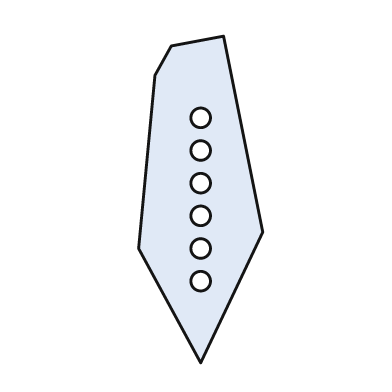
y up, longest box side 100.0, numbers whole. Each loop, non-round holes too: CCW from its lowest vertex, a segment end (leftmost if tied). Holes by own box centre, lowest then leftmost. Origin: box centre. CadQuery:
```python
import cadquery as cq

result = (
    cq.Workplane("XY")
    .moveTo(0.0, -50.0)
    .lineTo(19.0, -10.0)
    .lineTo(7.0, 50.0)
    .lineTo(-9.0, 47.0)
    .lineTo(-14.0, 38.0)
    .lineTo(-19.0, -15.0)
    .close()
    .moveTo(0.0, -25.0)
    .circle(3.0)
    .moveTo(0.0, -15.0)
    .circle(3.0)
    .moveTo(0.0, -5.0)
    .circle(3.0)
    .moveTo(0.0, 5.0)
    .circle(3.0)
    .moveTo(0.0, 15.0)
    .circle(3.0)
    .moveTo(0.0, 25.0)
    .circle(3.0)
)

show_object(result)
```